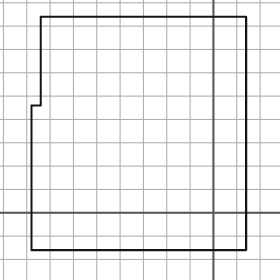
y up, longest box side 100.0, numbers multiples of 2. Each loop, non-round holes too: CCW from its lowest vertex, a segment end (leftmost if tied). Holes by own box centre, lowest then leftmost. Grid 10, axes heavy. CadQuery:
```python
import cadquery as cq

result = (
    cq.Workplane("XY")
    .moveTo(-78.0, -16.0)
    .lineTo(14.0, -16.0)
    .lineTo(14.0, 84.0)
    .lineTo(-74.0, 84.0)
    .lineTo(-74.0, 46.0)
    .lineTo(-78.0, 46.0)
    .close()
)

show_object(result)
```